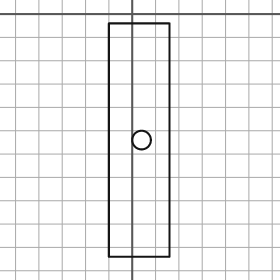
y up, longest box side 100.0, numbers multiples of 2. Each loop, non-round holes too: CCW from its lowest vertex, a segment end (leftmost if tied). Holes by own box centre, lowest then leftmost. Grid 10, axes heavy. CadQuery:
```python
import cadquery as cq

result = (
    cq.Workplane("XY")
    .moveTo(-10.0, -104.0)
    .lineTo(16.0, -104.0)
    .lineTo(16.0, -4.0)
    .lineTo(-10.0, -4.0)
    .close()
    .moveTo(4.0, -54.0)
    .circle(4.0)
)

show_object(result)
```